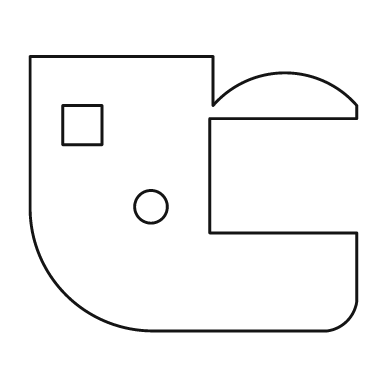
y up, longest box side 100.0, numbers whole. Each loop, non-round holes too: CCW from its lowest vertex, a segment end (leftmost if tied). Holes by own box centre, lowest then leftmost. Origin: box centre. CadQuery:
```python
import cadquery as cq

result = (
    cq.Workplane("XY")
    .moveTo(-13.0, -42.0)
    .lineTo(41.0, -42.0)
    .threePointArc((47.0, -39.0), (50.0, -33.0))
    .lineTo(50.0, -12.0)
    .lineTo(5.0, -12.0)
    .lineTo(5.0, 23.0)
    .lineTo(50.0, 23.0)
    .lineTo(50.0, 27.0)
    .threePointArc((28.0, 37.0), (6.0, 27.0))
    .lineTo(6.0, 42.0)
    .lineTo(-50.0, 42.0)
    .lineTo(-50.0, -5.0)
    .threePointArc((-39.0, -31.0), (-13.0, -42.0))
    .close()
    .moveTo(-13.0, -4.0)
    .circle(5.0)
    .moveTo(-40.0, 15.0)
    .lineTo(-28.0, 15.0)
    .lineTo(-28.0, 27.0)
    .lineTo(-40.0, 27.0)
    .close()
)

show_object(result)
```